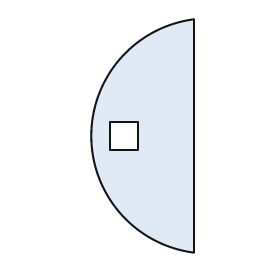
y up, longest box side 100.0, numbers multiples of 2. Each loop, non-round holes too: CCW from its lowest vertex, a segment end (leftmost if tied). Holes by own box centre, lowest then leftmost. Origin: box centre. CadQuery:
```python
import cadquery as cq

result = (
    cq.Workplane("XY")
    .moveTo(22.0, -50.0)
    .lineTo(22.0, 50.0)
    .threePointArc((-22.0, 0.0), (22.0, -50.0))
    .close()
    .moveTo(-14.0, -6.0)
    .lineTo(-2.0, -6.0)
    .lineTo(-2.0, 6.0)
    .lineTo(-14.0, 6.0)
    .close()
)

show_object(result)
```